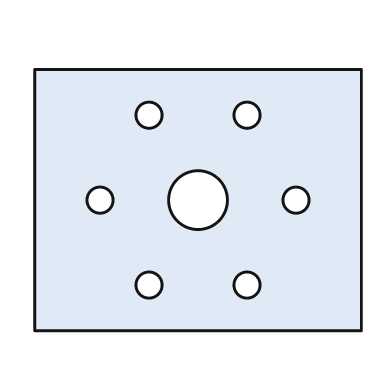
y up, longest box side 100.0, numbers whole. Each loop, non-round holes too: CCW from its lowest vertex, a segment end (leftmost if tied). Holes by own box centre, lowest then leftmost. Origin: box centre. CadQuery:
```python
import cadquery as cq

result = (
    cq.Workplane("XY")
    .moveTo(-50.0, -40.0)
    .lineTo(50.0, -40.0)
    .lineTo(50.0, 40.0)
    .lineTo(-50.0, 40.0)
    .close()
    .moveTo(-15.0, -26.0)
    .circle(4.0)
    .moveTo(15.0, -26.0)
    .circle(4.0)
    .moveTo(-30.0, 0.0)
    .circle(4.0)
    .moveTo(0.0, 0.0)
    .circle(9.0)
    .moveTo(30.0, 0.0)
    .circle(4.0)
    .moveTo(-15.0, 26.0)
    .circle(4.0)
    .moveTo(15.0, 26.0)
    .circle(4.0)
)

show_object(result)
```